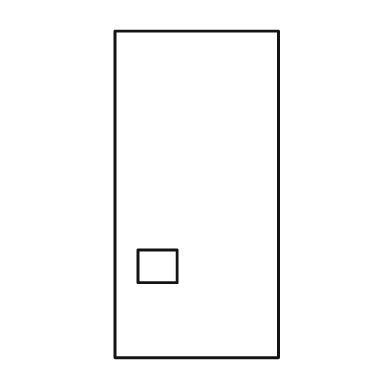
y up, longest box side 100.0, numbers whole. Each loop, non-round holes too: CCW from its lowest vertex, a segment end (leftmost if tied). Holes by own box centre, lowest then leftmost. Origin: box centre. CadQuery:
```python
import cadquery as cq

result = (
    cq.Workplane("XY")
    .moveTo(-25.0, -50.0)
    .lineTo(25.0, -50.0)
    .lineTo(25.0, 50.0)
    .lineTo(-25.0, 50.0)
    .close()
    .moveTo(-18.0, -27.0)
    .lineTo(-6.0, -27.0)
    .lineTo(-6.0, -17.0)
    .lineTo(-18.0, -17.0)
    .close()
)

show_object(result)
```